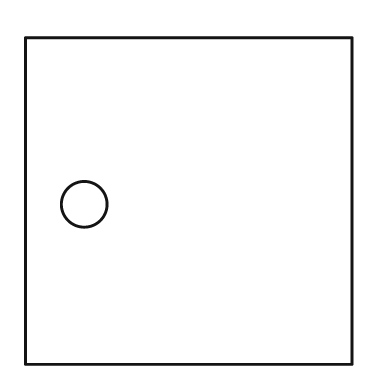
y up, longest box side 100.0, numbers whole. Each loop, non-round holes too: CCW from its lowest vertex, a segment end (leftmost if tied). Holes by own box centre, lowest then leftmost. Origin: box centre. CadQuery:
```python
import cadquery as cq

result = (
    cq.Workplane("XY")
    .moveTo(-50.0, -50.0)
    .lineTo(50.0, -50.0)
    .lineTo(50.0, 50.0)
    .lineTo(-50.0, 50.0)
    .close()
    .moveTo(-32.0, -1.0)
    .circle(7.0)
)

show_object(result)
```